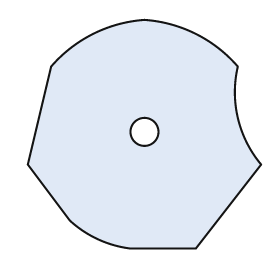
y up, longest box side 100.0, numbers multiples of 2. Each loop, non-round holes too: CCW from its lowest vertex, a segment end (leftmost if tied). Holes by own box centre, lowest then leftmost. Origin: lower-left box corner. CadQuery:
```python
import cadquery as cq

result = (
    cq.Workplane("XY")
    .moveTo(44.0, 0.0)
    .lineTo(72.0, 0.0)
    .lineTo(100.0, 36.0)
    .threePointArc((90.0, 56.0), (90.0, 78.0))
    .threePointArc((72.0, 92.0), (50.0, 98.0))
    .threePointArc((28.0, 92.0), (10.0, 78.0))
    .lineTo(0.0, 36.0)
    .lineTo(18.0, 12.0)
    .threePointArc((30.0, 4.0), (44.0, 0.0))
    .close()
    .moveTo(50.0, 50.0)
    .circle(6.0)
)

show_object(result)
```